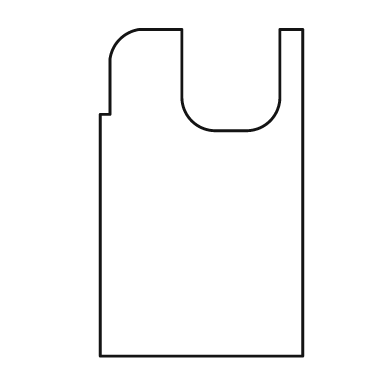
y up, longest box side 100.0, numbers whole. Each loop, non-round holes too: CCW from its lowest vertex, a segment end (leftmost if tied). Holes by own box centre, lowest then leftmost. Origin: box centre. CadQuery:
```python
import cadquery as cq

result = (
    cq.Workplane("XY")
    .moveTo(-31.0, -50.0)
    .lineTo(31.0, -50.0)
    .lineTo(31.0, 50.0)
    .lineTo(24.0, 50.0)
    .lineTo(24.0, 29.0)
    .threePointArc((21.0, 22.0), (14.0, 19.0))
    .lineTo(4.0, 19.0)
    .threePointArc((-3.0, 22.0), (-6.0, 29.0))
    .lineTo(-6.0, 50.0)
    .lineTo(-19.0, 50.0)
    .threePointArc((-25.0, 47.0), (-28.0, 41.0))
    .lineTo(-28.0, 24.0)
    .lineTo(-31.0, 24.0)
    .close()
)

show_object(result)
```